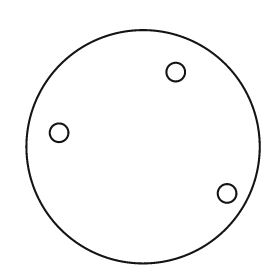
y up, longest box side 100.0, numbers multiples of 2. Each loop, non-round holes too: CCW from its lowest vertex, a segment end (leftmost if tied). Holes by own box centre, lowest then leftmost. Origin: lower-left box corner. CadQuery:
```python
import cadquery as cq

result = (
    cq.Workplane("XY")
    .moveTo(50.0, 50.0)
    .circle(50.0)
    .moveTo(86.0, 30.0)
    .circle(4.0)
    .moveTo(14.0, 56.0)
    .circle(4.0)
    .moveTo(64.0, 82.0)
    .circle(4.0)
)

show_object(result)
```